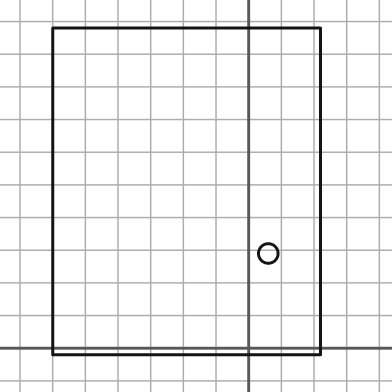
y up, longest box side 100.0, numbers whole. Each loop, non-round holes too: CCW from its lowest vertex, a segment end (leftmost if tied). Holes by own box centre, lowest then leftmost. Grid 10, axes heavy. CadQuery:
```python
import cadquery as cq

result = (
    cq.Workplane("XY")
    .moveTo(-60.0, -2.0)
    .lineTo(22.0, -2.0)
    .lineTo(22.0, 98.0)
    .lineTo(-60.0, 98.0)
    .close()
    .moveTo(6.0, 29.0)
    .circle(3.0)
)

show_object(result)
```